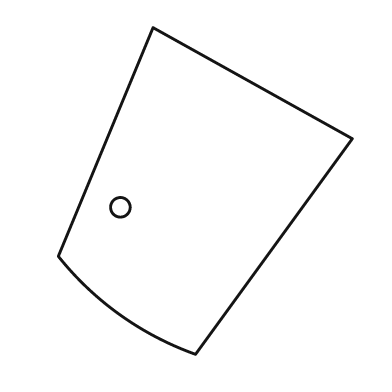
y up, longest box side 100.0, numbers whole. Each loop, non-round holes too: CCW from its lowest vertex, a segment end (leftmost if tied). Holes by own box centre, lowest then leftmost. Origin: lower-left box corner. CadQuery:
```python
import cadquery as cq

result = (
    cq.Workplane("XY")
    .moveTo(42.0, 0.0)
    .lineTo(90.0, 66.0)
    .lineTo(29.0, 100.0)
    .lineTo(0.0, 30.0)
    .threePointArc((19.0, 12.0), (42.0, 0.0))
    .close()
    .moveTo(19.0, 45.0)
    .circle(3.0)
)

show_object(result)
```